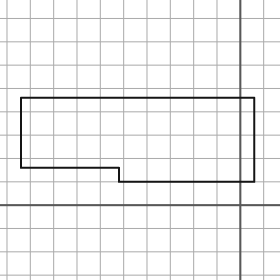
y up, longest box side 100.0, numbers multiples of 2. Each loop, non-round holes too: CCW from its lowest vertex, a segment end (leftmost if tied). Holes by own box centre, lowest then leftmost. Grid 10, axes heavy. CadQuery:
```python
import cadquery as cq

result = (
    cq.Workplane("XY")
    .moveTo(-52.0, 10.0)
    .lineTo(6.0, 10.0)
    .lineTo(6.0, 46.0)
    .lineTo(-94.0, 46.0)
    .lineTo(-94.0, 16.0)
    .lineTo(-52.0, 16.0)
    .close()
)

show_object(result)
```